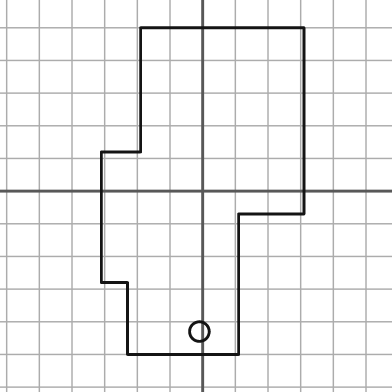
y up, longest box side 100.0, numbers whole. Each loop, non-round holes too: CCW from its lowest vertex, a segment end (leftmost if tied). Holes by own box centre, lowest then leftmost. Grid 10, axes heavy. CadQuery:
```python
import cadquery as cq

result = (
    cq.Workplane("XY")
    .moveTo(-23.0, -50.0)
    .lineTo(11.0, -50.0)
    .lineTo(11.0, -7.0)
    .lineTo(31.0, -7.0)
    .lineTo(31.0, 50.0)
    .lineTo(-19.0, 50.0)
    .lineTo(-19.0, 12.0)
    .lineTo(-31.0, 12.0)
    .lineTo(-31.0, -28.0)
    .lineTo(-23.0, -28.0)
    .close()
    .moveTo(-1.0, -43.0)
    .circle(3.0)
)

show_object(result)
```